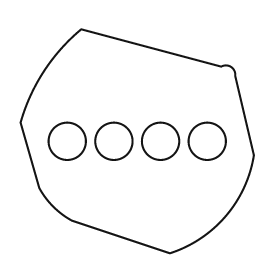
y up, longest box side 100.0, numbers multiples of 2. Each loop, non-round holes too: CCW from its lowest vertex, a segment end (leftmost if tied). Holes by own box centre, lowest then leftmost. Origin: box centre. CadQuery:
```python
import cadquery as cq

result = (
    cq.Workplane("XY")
    .moveTo(14.0, -48.0)
    .threePointArc((38.0, -32.0), (50.0, -6.0))
    .lineTo(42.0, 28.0)
    .threePointArc((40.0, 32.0), (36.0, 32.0))
    .lineTo(-24.0, 48.0)
    .threePointArc((-40.0, 30.0), (-50.0, 8.0))
    .lineTo(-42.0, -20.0)
    .threePointArc((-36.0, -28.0), (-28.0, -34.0))
    .close()
    .moveTo(-30.0, 0.0)
    .circle(8.0)
    .moveTo(-10.0, 0.0)
    .circle(8.0)
    .moveTo(10.0, 0.0)
    .circle(8.0)
    .moveTo(30.0, 0.0)
    .circle(8.0)
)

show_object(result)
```